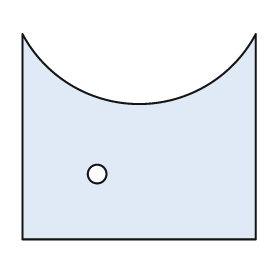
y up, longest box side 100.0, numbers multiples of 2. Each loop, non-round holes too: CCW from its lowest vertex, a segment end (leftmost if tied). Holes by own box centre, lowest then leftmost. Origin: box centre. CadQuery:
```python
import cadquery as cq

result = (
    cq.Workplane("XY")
    .moveTo(-50.0, -44.0)
    .lineTo(50.0, -44.0)
    .lineTo(50.0, 44.0)
    .threePointArc((0.0, 14.0), (-50.0, 44.0))
    .close()
    .moveTo(-18.0, -16.0)
    .circle(4.0)
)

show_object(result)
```